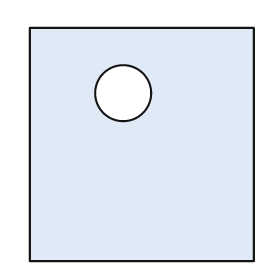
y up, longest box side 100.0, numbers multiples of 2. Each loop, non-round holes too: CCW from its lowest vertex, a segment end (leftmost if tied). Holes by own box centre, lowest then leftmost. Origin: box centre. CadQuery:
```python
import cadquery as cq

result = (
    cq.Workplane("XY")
    .moveTo(-48.0, -50.0)
    .lineTo(48.0, -50.0)
    .lineTo(48.0, 50.0)
    .lineTo(-48.0, 50.0)
    .close()
    .moveTo(-8.0, 22.0)
    .circle(12.0)
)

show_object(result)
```